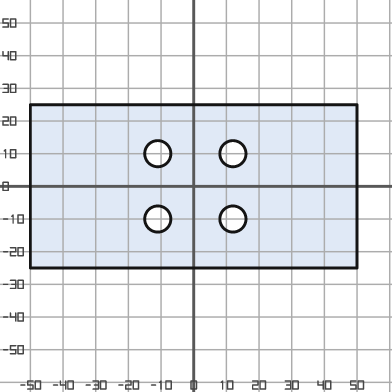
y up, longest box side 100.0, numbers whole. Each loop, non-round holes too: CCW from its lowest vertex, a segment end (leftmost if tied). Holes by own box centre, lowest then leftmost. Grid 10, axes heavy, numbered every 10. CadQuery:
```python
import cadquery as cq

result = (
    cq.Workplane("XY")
    .moveTo(-50.0, -25.0)
    .lineTo(50.0, -25.0)
    .lineTo(50.0, 25.0)
    .lineTo(-50.0, 25.0)
    .close()
    .moveTo(-11.0, -10.0)
    .circle(4.0)
    .moveTo(12.0, -10.0)
    .circle(4.0)
    .moveTo(-11.0, 10.0)
    .circle(4.0)
    .moveTo(12.0, 10.0)
    .circle(4.0)
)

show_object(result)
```